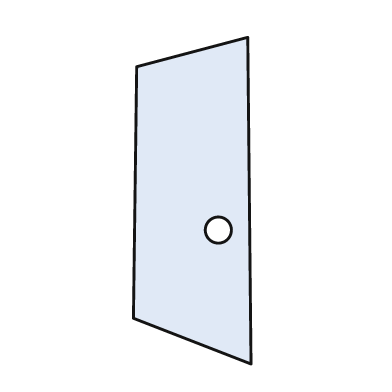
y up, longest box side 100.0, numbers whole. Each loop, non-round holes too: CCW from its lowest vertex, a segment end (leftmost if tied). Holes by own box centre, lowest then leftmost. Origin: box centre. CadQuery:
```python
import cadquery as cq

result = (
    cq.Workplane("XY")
    .moveTo(18.0, -50.0)
    .lineTo(17.0, 50.0)
    .lineTo(-17.0, 41.0)
    .lineTo(-18.0, -36.0)
    .close()
    .moveTo(8.0, -9.0)
    .circle(4.0)
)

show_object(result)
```